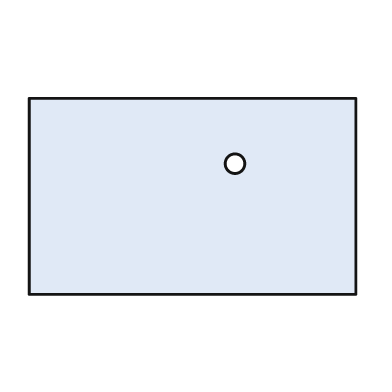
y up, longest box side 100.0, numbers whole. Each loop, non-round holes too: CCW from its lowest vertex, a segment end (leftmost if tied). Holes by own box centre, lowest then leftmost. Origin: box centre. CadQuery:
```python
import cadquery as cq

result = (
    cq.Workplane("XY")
    .moveTo(-50.0, -30.0)
    .lineTo(50.0, -30.0)
    .lineTo(50.0, 30.0)
    .lineTo(-50.0, 30.0)
    .close()
    .moveTo(13.0, 10.0)
    .circle(3.0)
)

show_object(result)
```